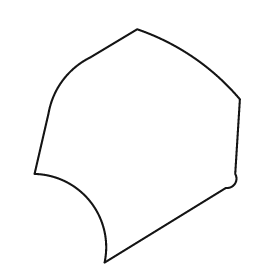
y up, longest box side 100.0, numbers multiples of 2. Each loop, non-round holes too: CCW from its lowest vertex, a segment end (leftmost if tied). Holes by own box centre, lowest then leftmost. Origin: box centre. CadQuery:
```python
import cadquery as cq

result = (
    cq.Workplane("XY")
    .moveTo(-14.0, -50.0)
    .lineTo(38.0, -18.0)
    .threePointArc((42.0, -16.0), (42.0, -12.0))
    .lineTo(44.0, 20.0)
    .threePointArc((24.0, 38.0), (0.0, 50.0))
    .lineTo(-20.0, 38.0)
    .threePointArc((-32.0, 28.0), (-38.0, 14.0))
    .lineTo(-44.0, -12.0)
    .threePointArc((-20.0, -24.0), (-14.0, -50.0))
    .close()
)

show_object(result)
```